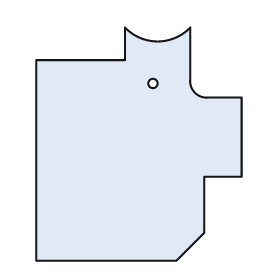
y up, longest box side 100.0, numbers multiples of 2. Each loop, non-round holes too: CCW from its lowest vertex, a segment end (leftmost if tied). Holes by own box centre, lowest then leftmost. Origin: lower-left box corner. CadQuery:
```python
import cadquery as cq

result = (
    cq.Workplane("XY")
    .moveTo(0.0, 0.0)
    .lineTo(60.0, 0.0)
    .lineTo(72.0, 12.0)
    .lineTo(72.0, 36.0)
    .lineTo(88.0, 36.0)
    .lineTo(88.0, 70.0)
    .lineTo(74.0, 70.0)
    .threePointArc((68.0, 72.0), (66.0, 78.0))
    .lineTo(66.0, 100.0)
    .threePointArc((52.0, 94.0), (38.0, 100.0))
    .lineTo(38.0, 86.0)
    .lineTo(0.0, 86.0)
    .close()
    .moveTo(50.0, 76.0)
    .circle(2.0)
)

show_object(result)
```